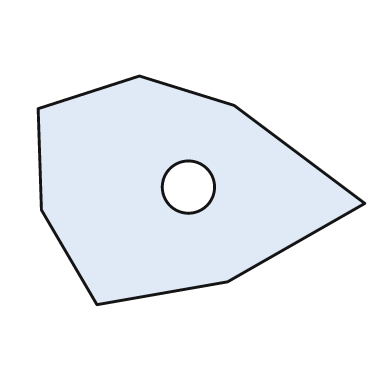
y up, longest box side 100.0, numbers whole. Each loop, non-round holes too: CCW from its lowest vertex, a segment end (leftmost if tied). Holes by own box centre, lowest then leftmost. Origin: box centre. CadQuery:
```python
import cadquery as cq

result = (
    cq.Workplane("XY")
    .moveTo(-32.0, -35.0)
    .lineTo(8.0, -28.0)
    .lineTo(50.0, -4.0)
    .lineTo(10.0, 26.0)
    .lineTo(-19.0, 35.0)
    .lineTo(-50.0, 25.0)
    .lineTo(-49.0, -6.0)
    .close()
    .moveTo(-4.0, 1.0)
    .circle(8.0)
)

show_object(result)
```